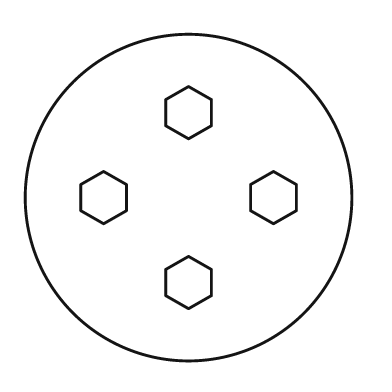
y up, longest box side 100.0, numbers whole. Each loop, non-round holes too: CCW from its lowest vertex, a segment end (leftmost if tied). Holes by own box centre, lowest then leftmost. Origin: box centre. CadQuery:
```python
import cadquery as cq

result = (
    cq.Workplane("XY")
    .moveTo(0.0, 0.0)
    .circle(50.0)
    .moveTo(0.0, -34.0)
    .lineTo(7.0, -30.0)
    .lineTo(7.0, -22.0)
    .lineTo(0.0, -18.0)
    .lineTo(-7.0, -22.0)
    .lineTo(-7.0, -30.0)
    .close()
    .moveTo(-26.0, -8.0)
    .lineTo(-19.0, -4.0)
    .lineTo(-19.0, 4.0)
    .lineTo(-26.0, 8.0)
    .lineTo(-33.0, 4.0)
    .lineTo(-33.0, -4.0)
    .close()
    .moveTo(26.0, -8.0)
    .lineTo(33.0, -4.0)
    .lineTo(33.0, 4.0)
    .lineTo(26.0, 8.0)
    .lineTo(19.0, 4.0)
    .lineTo(19.0, -4.0)
    .close()
    .moveTo(0.0, 18.0)
    .lineTo(7.0, 22.0)
    .lineTo(7.0, 30.0)
    .lineTo(0.0, 34.0)
    .lineTo(-7.0, 30.0)
    .lineTo(-7.0, 22.0)
    .close()
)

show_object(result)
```